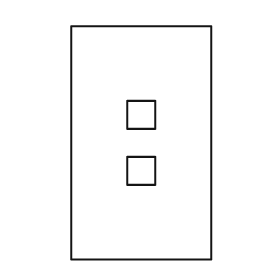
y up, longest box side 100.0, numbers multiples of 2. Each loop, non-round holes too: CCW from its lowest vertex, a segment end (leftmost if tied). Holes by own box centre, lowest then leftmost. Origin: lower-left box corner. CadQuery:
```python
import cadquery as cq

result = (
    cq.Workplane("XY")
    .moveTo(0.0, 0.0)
    .lineTo(60.0, 0.0)
    .lineTo(60.0, 100.0)
    .lineTo(0.0, 100.0)
    .close()
    .moveTo(24.0, 32.0)
    .lineTo(36.0, 32.0)
    .lineTo(36.0, 44.0)
    .lineTo(24.0, 44.0)
    .close()
    .moveTo(24.0, 56.0)
    .lineTo(36.0, 56.0)
    .lineTo(36.0, 68.0)
    .lineTo(24.0, 68.0)
    .close()
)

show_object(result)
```